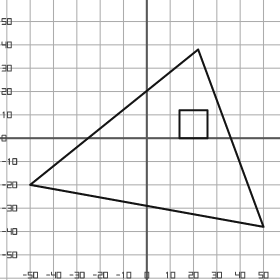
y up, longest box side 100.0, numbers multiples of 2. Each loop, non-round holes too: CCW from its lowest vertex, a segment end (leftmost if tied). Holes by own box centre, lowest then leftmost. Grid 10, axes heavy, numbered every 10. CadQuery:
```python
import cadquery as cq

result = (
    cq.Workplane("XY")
    .moveTo(50.0, -38.0)
    .lineTo(22.0, 38.0)
    .lineTo(-50.0, -20.0)
    .close()
    .moveTo(14.0, 0.0)
    .lineTo(26.0, 0.0)
    .lineTo(26.0, 12.0)
    .lineTo(14.0, 12.0)
    .close()
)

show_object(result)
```